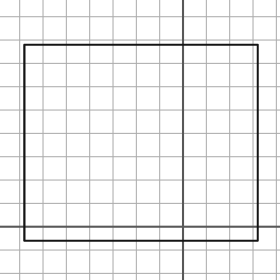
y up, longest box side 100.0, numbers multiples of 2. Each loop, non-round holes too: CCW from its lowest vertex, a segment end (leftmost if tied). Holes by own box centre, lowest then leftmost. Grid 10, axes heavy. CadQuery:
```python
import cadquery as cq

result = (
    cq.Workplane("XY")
    .moveTo(-68.0, -6.0)
    .lineTo(32.0, -6.0)
    .lineTo(32.0, 78.0)
    .lineTo(-68.0, 78.0)
    .close()
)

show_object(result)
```